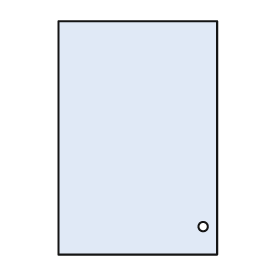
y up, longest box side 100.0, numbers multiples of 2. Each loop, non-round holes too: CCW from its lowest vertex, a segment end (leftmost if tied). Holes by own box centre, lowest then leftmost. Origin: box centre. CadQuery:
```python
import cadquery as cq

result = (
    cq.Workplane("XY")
    .moveTo(-34.0, -50.0)
    .lineTo(34.0, -50.0)
    .lineTo(34.0, 50.0)
    .lineTo(-34.0, 50.0)
    .close()
    .moveTo(28.0, -38.0)
    .circle(2.0)
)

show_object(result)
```